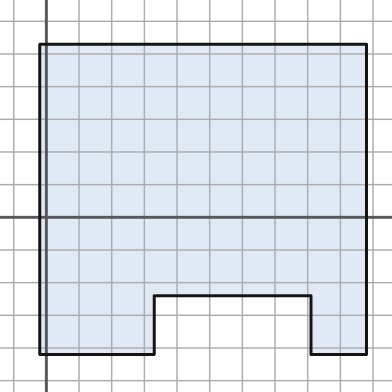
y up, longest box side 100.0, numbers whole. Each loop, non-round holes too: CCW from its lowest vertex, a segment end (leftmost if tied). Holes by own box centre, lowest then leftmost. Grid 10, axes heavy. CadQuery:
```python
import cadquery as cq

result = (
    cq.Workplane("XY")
    .moveTo(-2.0, -42.0)
    .lineTo(33.0, -42.0)
    .lineTo(33.0, -24.0)
    .lineTo(81.0, -24.0)
    .lineTo(81.0, -42.0)
    .lineTo(98.0, -42.0)
    .lineTo(98.0, 53.0)
    .lineTo(-2.0, 53.0)
    .close()
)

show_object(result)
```